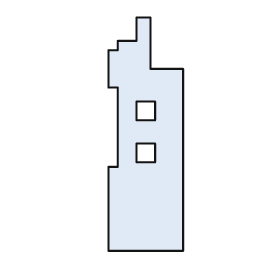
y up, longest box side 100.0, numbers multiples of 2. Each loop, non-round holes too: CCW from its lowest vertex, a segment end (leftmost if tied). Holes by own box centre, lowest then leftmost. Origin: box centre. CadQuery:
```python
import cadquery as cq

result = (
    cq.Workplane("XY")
    .moveTo(-16.0, -50.0)
    .lineTo(16.0, -50.0)
    .lineTo(16.0, 28.0)
    .lineTo(2.0, 28.0)
    .lineTo(2.0, 50.0)
    .lineTo(-4.0, 50.0)
    .lineTo(-4.0, 40.0)
    .lineTo(-12.0, 40.0)
    .lineTo(-12.0, 36.0)
    .lineTo(-16.0, 36.0)
    .lineTo(-16.0, 20.0)
    .lineTo(-12.0, 20.0)
    .lineTo(-12.0, -14.0)
    .lineTo(-16.0, -14.0)
    .close()
    .moveTo(-4.0, -12.0)
    .lineTo(4.0, -12.0)
    .lineTo(4.0, -4.0)
    .lineTo(-4.0, -4.0)
    .close()
    .moveTo(-4.0, 6.0)
    .lineTo(4.0, 6.0)
    .lineTo(4.0, 14.0)
    .lineTo(-4.0, 14.0)
    .close()
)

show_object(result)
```